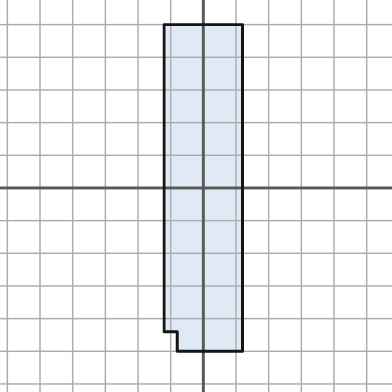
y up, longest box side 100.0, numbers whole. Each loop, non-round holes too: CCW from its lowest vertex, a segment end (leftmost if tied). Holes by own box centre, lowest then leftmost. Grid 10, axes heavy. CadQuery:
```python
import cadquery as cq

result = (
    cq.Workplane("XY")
    .moveTo(-8.0, -50.0)
    .lineTo(12.0, -50.0)
    .lineTo(12.0, 50.0)
    .lineTo(-12.0, 50.0)
    .lineTo(-12.0, -44.0)
    .lineTo(-8.0, -44.0)
    .close()
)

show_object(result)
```